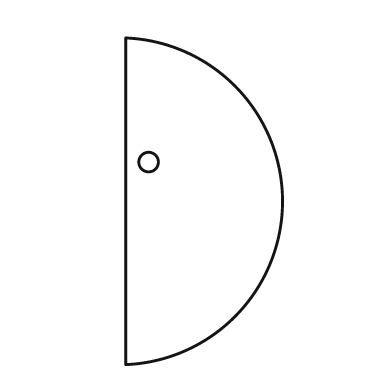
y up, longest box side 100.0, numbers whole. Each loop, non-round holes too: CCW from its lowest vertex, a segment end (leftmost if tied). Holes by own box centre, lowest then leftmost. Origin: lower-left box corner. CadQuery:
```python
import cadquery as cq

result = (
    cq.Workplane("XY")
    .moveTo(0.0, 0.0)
    .threePointArc((48.0, 50.0), (0.0, 100.0))
    .close()
    .moveTo(7.0, 62.0)
    .circle(3.0)
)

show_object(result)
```